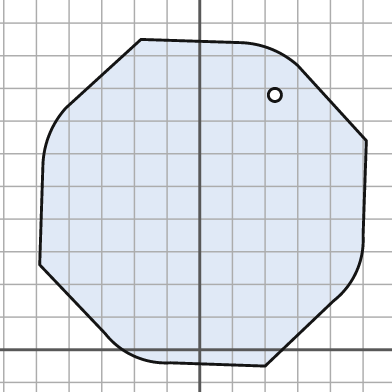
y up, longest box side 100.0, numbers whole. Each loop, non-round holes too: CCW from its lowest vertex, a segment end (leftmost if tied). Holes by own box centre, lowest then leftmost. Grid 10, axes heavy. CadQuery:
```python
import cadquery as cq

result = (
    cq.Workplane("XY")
    .moveTo(20.0, -5.0)
    .lineTo(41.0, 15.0)
    .threePointArc((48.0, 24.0), (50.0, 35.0))
    .lineTo(51.0, 64.0)
    .lineTo(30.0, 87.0)
    .threePointArc((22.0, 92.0), (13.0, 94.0))
    .lineTo(-18.0, 95.0)
    .lineTo(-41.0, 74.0)
    .threePointArc((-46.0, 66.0), (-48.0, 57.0))
    .lineTo(-49.0, 26.0)
    .lineTo(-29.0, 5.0)
    .threePointArc((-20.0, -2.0), (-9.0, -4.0))
    .close()
    .moveTo(23.0, 78.0)
    .circle(2.0)
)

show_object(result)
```